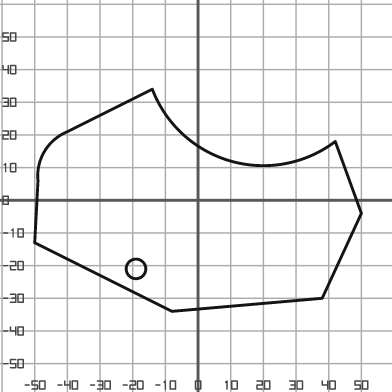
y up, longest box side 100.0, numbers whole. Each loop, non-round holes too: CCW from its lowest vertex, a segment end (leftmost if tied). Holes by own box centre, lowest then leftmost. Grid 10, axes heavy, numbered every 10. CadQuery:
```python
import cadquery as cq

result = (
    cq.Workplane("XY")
    .moveTo(-8.0, -34.0)
    .lineTo(38.0, -30.0)
    .lineTo(50.0, -4.0)
    .lineTo(42.0, 18.0)
    .threePointArc((10.0, 12.0), (-14.0, 34.0))
    .lineTo(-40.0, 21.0)
    .threePointArc((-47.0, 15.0), (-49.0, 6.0))
    .lineTo(-50.0, -13.0)
    .close()
    .moveTo(-19.0, -21.0)
    .circle(3.0)
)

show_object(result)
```